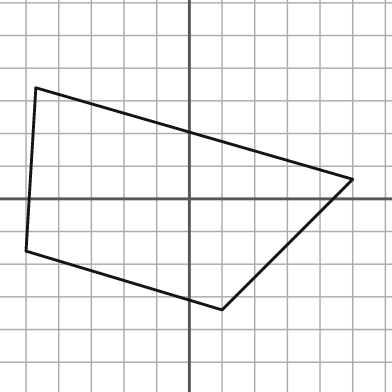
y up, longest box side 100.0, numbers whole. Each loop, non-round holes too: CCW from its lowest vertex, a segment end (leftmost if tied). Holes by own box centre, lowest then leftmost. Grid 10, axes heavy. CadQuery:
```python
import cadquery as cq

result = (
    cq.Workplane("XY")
    .moveTo(10.0, -34.0)
    .lineTo(50.0, 6.0)
    .lineTo(-47.0, 34.0)
    .lineTo(-50.0, -16.0)
    .close()
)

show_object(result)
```